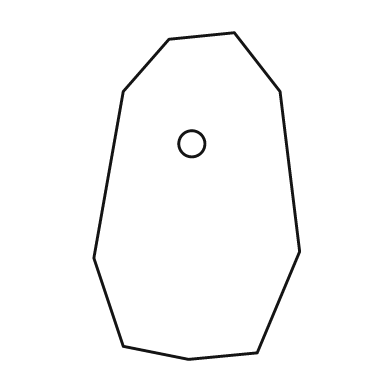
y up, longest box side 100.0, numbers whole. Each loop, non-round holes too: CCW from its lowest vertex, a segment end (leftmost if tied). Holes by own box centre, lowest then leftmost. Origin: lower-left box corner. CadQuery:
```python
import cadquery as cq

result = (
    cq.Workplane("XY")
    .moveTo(29.0, 0.0)
    .lineTo(50.0, 2.0)
    .lineTo(63.0, 33.0)
    .lineTo(57.0, 82.0)
    .lineTo(43.0, 100.0)
    .lineTo(23.0, 98.0)
    .lineTo(9.0, 82.0)
    .lineTo(0.0, 31.0)
    .lineTo(9.0, 4.0)
    .close()
    .moveTo(30.0, 66.0)
    .circle(4.0)
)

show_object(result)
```